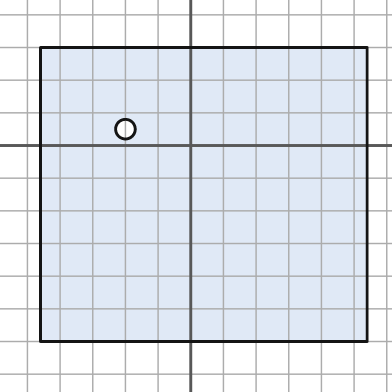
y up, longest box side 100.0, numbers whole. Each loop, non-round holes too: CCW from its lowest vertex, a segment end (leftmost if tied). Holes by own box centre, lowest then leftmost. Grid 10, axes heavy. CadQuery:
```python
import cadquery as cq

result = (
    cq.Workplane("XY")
    .moveTo(-46.0, -60.0)
    .lineTo(54.0, -60.0)
    .lineTo(54.0, 30.0)
    .lineTo(-46.0, 30.0)
    .close()
    .moveTo(-20.0, 5.0)
    .circle(3.0)
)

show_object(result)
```